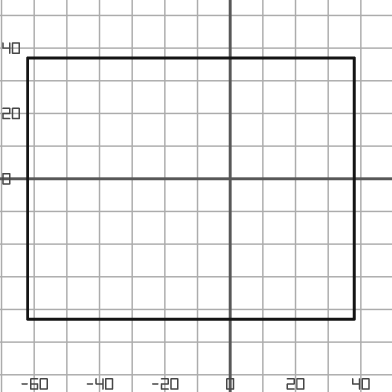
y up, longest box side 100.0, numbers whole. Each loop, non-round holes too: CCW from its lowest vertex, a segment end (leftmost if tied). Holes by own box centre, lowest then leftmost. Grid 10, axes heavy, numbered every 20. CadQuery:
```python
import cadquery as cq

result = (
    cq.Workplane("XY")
    .moveTo(-62.0, -43.0)
    .lineTo(38.0, -43.0)
    .lineTo(38.0, 37.0)
    .lineTo(-62.0, 37.0)
    .close()
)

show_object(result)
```